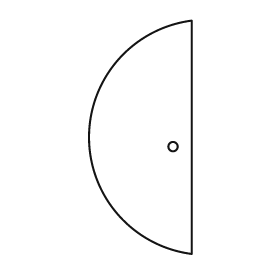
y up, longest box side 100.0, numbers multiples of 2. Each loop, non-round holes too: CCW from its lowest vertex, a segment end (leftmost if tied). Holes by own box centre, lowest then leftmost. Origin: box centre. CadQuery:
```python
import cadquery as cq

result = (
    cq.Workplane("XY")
    .moveTo(22.0, -50.0)
    .lineTo(22.0, 50.0)
    .threePointArc((-22.0, 0.0), (22.0, -50.0))
    .close()
    .moveTo(14.0, -4.0)
    .circle(2.0)
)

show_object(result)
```